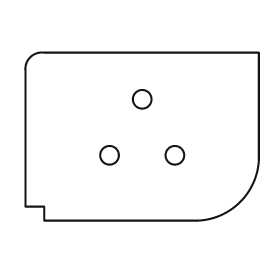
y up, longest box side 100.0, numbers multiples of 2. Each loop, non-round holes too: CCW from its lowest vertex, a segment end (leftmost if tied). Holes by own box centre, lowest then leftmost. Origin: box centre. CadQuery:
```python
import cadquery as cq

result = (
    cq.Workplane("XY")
    .moveTo(-42.0, -36.0)
    .lineTo(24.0, -36.0)
    .threePointArc((42.0, -28.0), (50.0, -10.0))
    .lineTo(50.0, 36.0)
    .lineTo(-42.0, 36.0)
    .threePointArc((-48.0, 34.0), (-50.0, 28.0))
    .lineTo(-50.0, -30.0)
    .lineTo(-42.0, -30.0)
    .close()
    .moveTo(-14.0, -8.0)
    .circle(4.0)
    .moveTo(14.0, -8.0)
    .circle(4.0)
    .moveTo(0.0, 16.0)
    .circle(4.0)
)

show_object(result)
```